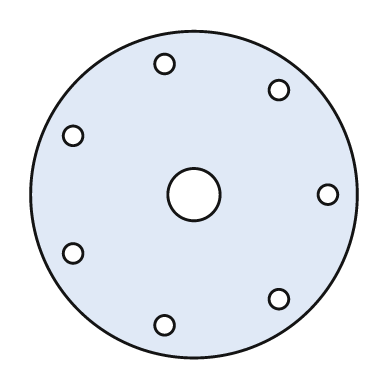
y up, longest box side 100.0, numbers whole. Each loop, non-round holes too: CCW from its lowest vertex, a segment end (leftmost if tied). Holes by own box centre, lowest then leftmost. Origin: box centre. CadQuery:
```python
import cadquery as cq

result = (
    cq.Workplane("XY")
    .moveTo(0.0, 0.0)
    .circle(50.0)
    .moveTo(-9.0, -40.0)
    .circle(3.0)
    .moveTo(26.0, -32.0)
    .circle(3.0)
    .moveTo(-37.0, -18.0)
    .circle(3.0)
    .moveTo(0.0, 0.0)
    .circle(8.0)
    .moveTo(41.0, 0.0)
    .circle(3.0)
    .moveTo(-37.0, 18.0)
    .circle(3.0)
    .moveTo(26.0, 32.0)
    .circle(3.0)
    .moveTo(-9.0, 40.0)
    .circle(3.0)
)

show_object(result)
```